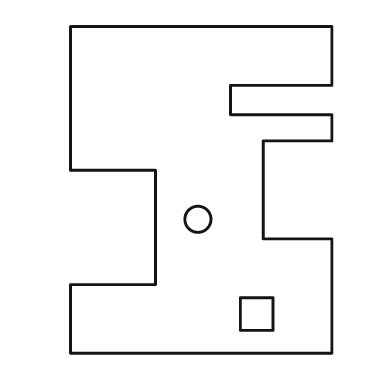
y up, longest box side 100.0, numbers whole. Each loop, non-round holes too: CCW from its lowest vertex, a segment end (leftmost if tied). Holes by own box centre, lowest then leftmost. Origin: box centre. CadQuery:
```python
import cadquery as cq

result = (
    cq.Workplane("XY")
    .moveTo(-40.0, -50.0)
    .lineTo(40.0, -50.0)
    .lineTo(40.0, -15.0)
    .lineTo(19.0, -15.0)
    .lineTo(19.0, 15.0)
    .lineTo(40.0, 15.0)
    .lineTo(40.0, 23.0)
    .lineTo(9.0, 23.0)
    .lineTo(9.0, 32.0)
    .lineTo(40.0, 32.0)
    .lineTo(40.0, 50.0)
    .lineTo(-40.0, 50.0)
    .lineTo(-40.0, 6.0)
    .lineTo(-14.0, 6.0)
    .lineTo(-14.0, -29.0)
    .lineTo(-40.0, -29.0)
    .close()
    .moveTo(12.0, -43.0)
    .lineTo(22.0, -43.0)
    .lineTo(22.0, -33.0)
    .lineTo(12.0, -33.0)
    .close()
    .moveTo(-1.0, -9.0)
    .circle(4.0)
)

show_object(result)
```